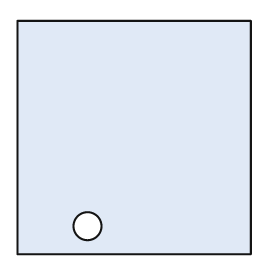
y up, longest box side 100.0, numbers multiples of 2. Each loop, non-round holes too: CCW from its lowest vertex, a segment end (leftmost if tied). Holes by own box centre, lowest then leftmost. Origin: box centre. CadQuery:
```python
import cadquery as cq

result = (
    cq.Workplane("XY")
    .moveTo(-50.0, -50.0)
    .lineTo(50.0, -50.0)
    .lineTo(50.0, 50.0)
    .lineTo(-50.0, 50.0)
    .close()
    .moveTo(-20.0, -38.0)
    .circle(6.0)
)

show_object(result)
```